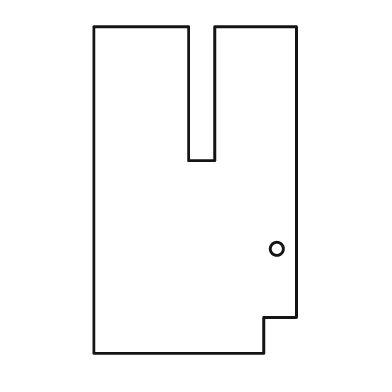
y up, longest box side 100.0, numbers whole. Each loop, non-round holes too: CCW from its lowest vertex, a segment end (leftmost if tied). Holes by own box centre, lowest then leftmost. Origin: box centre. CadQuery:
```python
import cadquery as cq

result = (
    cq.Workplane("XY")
    .moveTo(-31.0, -50.0)
    .lineTo(21.0, -50.0)
    .lineTo(21.0, -39.0)
    .lineTo(31.0, -39.0)
    .lineTo(31.0, 50.0)
    .lineTo(6.0, 50.0)
    .lineTo(6.0, 9.0)
    .lineTo(-2.0, 9.0)
    .lineTo(-2.0, 50.0)
    .lineTo(-31.0, 50.0)
    .close()
    .moveTo(25.0, -18.0)
    .circle(2.0)
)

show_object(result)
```